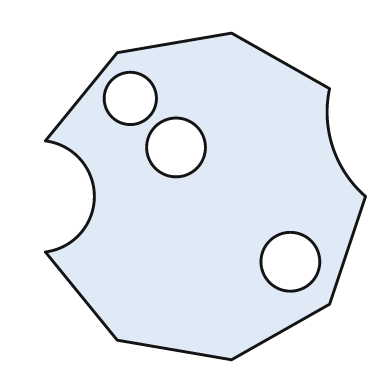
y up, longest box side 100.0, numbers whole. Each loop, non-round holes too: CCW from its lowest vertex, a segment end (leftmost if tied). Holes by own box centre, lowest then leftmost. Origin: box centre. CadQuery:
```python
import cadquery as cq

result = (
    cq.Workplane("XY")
    .moveTo(8.0, -50.0)
    .lineTo(38.0, -33.0)
    .lineTo(49.0, 0.0)
    .threePointArc((39.0, 15.0), (38.0, 33.0))
    .lineTo(8.0, 50.0)
    .lineTo(-27.0, 44.0)
    .lineTo(-49.0, 17.0)
    .threePointArc((-34.0, 0.0), (-49.0, -17.0))
    .lineTo(-27.0, -44.0)
    .close()
    .moveTo(26.0, -20.0)
    .circle(9.0)
    .moveTo(-9.0, 15.0)
    .circle(9.0)
    .moveTo(-23.0, 30.0)
    .circle(8.0)
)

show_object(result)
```